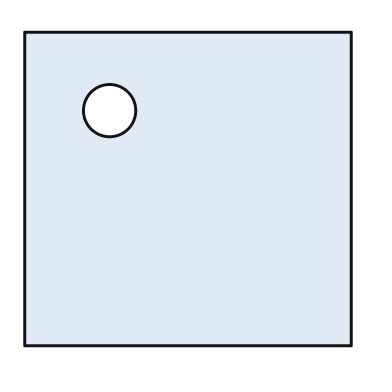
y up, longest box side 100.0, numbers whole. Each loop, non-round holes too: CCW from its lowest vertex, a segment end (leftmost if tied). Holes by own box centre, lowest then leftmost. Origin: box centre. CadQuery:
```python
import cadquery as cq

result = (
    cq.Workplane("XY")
    .moveTo(-50.0, -48.0)
    .lineTo(50.0, -48.0)
    .lineTo(50.0, 48.0)
    .lineTo(-50.0, 48.0)
    .close()
    .moveTo(-24.0, 24.0)
    .circle(8.0)
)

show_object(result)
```